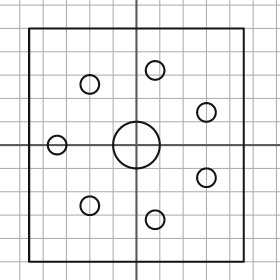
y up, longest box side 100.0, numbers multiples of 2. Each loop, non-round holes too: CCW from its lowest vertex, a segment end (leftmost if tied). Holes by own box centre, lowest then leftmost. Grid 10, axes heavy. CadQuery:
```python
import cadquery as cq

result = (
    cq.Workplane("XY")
    .moveTo(-46.0, -50.0)
    .lineTo(46.0, -50.0)
    .lineTo(46.0, 50.0)
    .lineTo(-46.0, 50.0)
    .close()
    .moveTo(8.0, -32.0)
    .circle(4.0)
    .moveTo(-20.0, -26.0)
    .circle(4.0)
    .moveTo(30.0, -14.0)
    .circle(4.0)
    .moveTo(-34.0, 0.0)
    .circle(4.0)
    .moveTo(0.0, 0.0)
    .circle(10.0)
    .moveTo(30.0, 14.0)
    .circle(4.0)
    .moveTo(-20.0, 26.0)
    .circle(4.0)
    .moveTo(8.0, 32.0)
    .circle(4.0)
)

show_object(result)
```